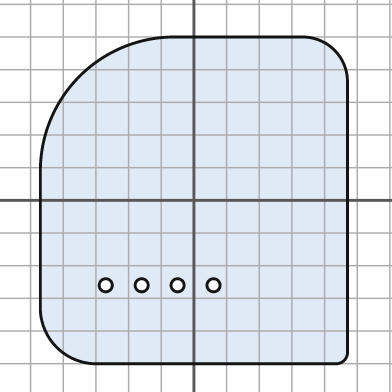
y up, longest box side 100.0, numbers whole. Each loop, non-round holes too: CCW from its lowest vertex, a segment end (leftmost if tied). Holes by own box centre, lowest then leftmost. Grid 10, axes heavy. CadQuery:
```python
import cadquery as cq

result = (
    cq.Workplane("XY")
    .moveTo(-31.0, -50.0)
    .lineTo(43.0, -50.0)
    .threePointArc((46.0, -49.0), (47.0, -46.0))
    .lineTo(47.0, 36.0)
    .threePointArc((43.0, 46.0), (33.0, 50.0))
    .lineTo(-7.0, 50.0)
    .threePointArc((-35.0, 38.0), (-47.0, 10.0))
    .lineTo(-47.0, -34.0)
    .threePointArc((-42.0, -45.0), (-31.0, -50.0))
    .close()
    .moveTo(-27.0, -26.0)
    .circle(2.0)
    .moveTo(-16.0, -26.0)
    .circle(2.0)
    .moveTo(-5.0, -26.0)
    .circle(2.0)
    .moveTo(6.0, -26.0)
    .circle(2.0)
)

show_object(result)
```